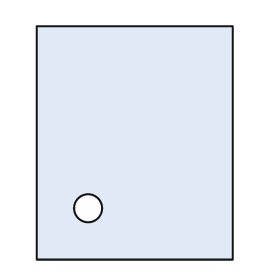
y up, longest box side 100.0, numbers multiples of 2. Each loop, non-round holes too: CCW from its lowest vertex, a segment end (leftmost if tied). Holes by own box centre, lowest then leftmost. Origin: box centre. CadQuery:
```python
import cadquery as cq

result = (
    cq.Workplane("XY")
    .moveTo(-42.0, -50.0)
    .lineTo(42.0, -50.0)
    .lineTo(42.0, 50.0)
    .lineTo(-42.0, 50.0)
    .close()
    .moveTo(-20.0, -28.0)
    .circle(6.0)
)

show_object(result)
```